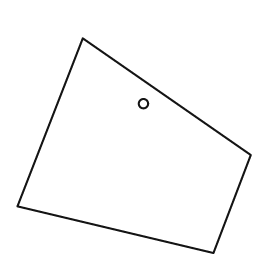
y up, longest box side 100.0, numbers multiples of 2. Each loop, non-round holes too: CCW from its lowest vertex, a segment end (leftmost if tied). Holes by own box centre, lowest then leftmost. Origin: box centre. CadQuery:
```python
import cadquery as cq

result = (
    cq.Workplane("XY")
    .moveTo(34.0, -46.0)
    .lineTo(50.0, -4.0)
    .lineTo(-22.0, 46.0)
    .lineTo(-50.0, -26.0)
    .close()
    .moveTo(4.0, 18.0)
    .circle(2.0)
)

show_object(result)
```